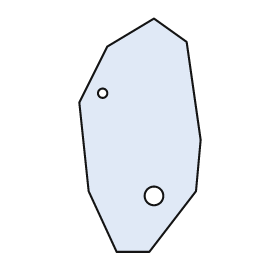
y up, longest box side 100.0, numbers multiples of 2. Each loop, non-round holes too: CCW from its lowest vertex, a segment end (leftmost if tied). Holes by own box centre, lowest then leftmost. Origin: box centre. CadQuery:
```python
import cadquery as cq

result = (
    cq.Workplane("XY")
    .moveTo(-10.0, -50.0)
    .lineTo(4.0, -50.0)
    .lineTo(24.0, -24.0)
    .lineTo(26.0, -2.0)
    .lineTo(20.0, 40.0)
    .lineTo(6.0, 50.0)
    .lineTo(-14.0, 38.0)
    .lineTo(-26.0, 14.0)
    .lineTo(-22.0, -24.0)
    .close()
    .moveTo(6.0, -26.0)
    .circle(4.0)
    .moveTo(-16.0, 18.0)
    .circle(2.0)
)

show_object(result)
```